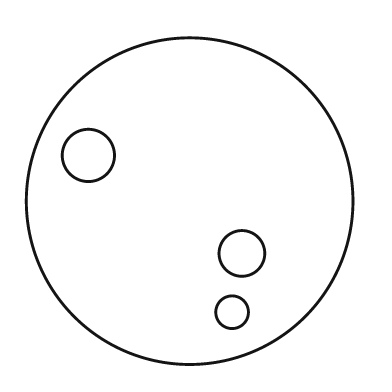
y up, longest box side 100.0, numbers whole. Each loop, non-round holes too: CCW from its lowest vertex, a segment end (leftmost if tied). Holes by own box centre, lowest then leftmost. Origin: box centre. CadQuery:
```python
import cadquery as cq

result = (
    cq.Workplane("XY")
    .moveTo(0.0, 0.0)
    .circle(50.0)
    .moveTo(13.0, -34.0)
    .circle(5.0)
    .moveTo(16.0, -16.0)
    .circle(7.0)
    .moveTo(-31.0, 14.0)
    .circle(8.0)
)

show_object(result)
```